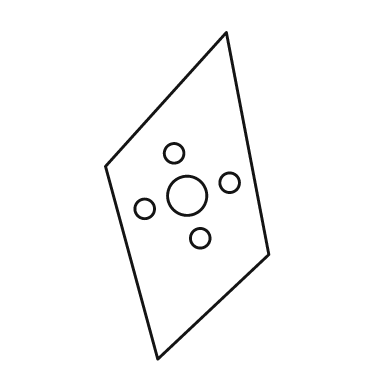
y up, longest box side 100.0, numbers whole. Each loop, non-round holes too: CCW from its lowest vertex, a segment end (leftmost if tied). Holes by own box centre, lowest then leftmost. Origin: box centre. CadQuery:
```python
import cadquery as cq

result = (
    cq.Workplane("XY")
    .moveTo(-9.0, -50.0)
    .lineTo(25.0, -18.0)
    .lineTo(12.0, 50.0)
    .lineTo(-25.0, 9.0)
    .close()
    .moveTo(4.0, -13.0)
    .circle(3.0)
    .moveTo(-13.0, -4.0)
    .circle(3.0)
    .moveTo(0.0, 0.0)
    .circle(6.0)
    .moveTo(13.0, 4.0)
    .circle(3.0)
    .moveTo(-4.0, 13.0)
    .circle(3.0)
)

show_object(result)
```